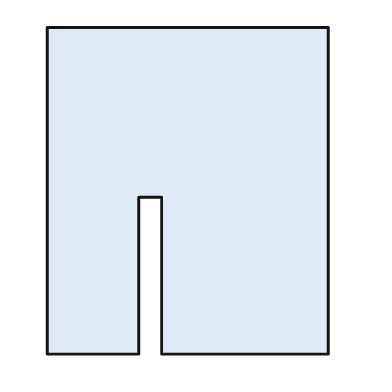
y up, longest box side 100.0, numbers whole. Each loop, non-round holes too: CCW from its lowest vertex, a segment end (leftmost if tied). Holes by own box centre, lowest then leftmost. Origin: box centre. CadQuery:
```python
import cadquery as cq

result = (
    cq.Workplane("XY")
    .moveTo(-43.0, -50.0)
    .lineTo(-15.0, -50.0)
    .lineTo(-15.0, -2.0)
    .lineTo(-8.0, -2.0)
    .lineTo(-8.0, -50.0)
    .lineTo(43.0, -50.0)
    .lineTo(43.0, 50.0)
    .lineTo(-43.0, 50.0)
    .close()
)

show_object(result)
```